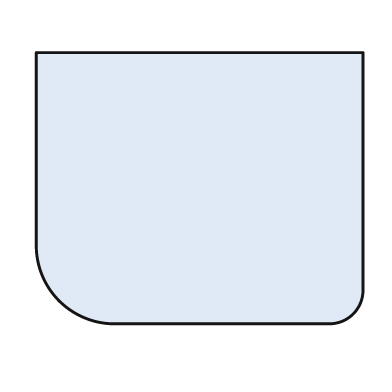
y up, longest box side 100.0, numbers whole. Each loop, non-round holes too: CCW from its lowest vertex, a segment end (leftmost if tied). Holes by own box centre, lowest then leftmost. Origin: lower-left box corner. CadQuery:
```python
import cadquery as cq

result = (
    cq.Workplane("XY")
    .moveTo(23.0, 0.0)
    .lineTo(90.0, 0.0)
    .threePointArc((97.0, 3.0), (100.0, 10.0))
    .lineTo(100.0, 83.0)
    .lineTo(0.0, 83.0)
    .lineTo(0.0, 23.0)
    .threePointArc((7.0, 7.0), (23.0, 0.0))
    .close()
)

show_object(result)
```